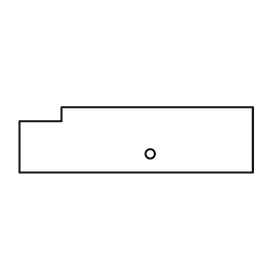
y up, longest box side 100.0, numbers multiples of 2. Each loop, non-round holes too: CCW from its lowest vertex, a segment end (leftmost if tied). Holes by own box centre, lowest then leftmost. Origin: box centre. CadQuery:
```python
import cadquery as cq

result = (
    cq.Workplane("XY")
    .moveTo(-50.0, -14.0)
    .lineTo(50.0, -14.0)
    .lineTo(50.0, 14.0)
    .lineTo(-32.0, 14.0)
    .lineTo(-32.0, 8.0)
    .lineTo(-50.0, 8.0)
    .close()
    .moveTo(6.0, -6.0)
    .circle(2.0)
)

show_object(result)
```